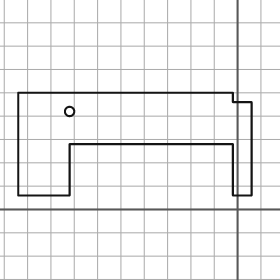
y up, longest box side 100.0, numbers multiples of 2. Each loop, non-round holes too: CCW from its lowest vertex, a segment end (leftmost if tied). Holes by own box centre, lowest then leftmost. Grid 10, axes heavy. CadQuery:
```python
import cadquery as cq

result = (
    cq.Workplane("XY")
    .moveTo(-94.0, 6.0)
    .lineTo(-72.0, 6.0)
    .lineTo(-72.0, 28.0)
    .lineTo(-2.0, 28.0)
    .lineTo(-2.0, 6.0)
    .lineTo(6.0, 6.0)
    .lineTo(6.0, 46.0)
    .lineTo(-2.0, 46.0)
    .lineTo(-2.0, 50.0)
    .lineTo(-94.0, 50.0)
    .close()
    .moveTo(-72.0, 42.0)
    .circle(2.0)
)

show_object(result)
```